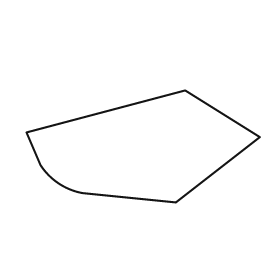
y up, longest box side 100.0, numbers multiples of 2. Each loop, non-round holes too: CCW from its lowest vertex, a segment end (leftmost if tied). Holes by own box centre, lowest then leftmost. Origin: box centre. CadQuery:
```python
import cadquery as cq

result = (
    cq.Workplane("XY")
    .moveTo(14.0, -24.0)
    .lineTo(50.0, 4.0)
    .lineTo(18.0, 24.0)
    .lineTo(-50.0, 6.0)
    .lineTo(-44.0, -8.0)
    .threePointArc((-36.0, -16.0), (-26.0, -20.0))
    .close()
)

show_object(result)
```